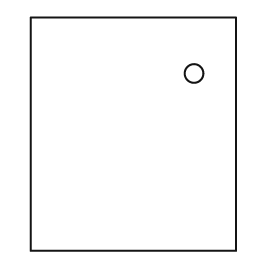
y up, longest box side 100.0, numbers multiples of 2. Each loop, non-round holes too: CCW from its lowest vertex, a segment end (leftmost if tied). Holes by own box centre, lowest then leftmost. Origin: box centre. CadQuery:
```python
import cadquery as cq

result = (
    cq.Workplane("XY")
    .moveTo(-44.0, -50.0)
    .lineTo(44.0, -50.0)
    .lineTo(44.0, 50.0)
    .lineTo(-44.0, 50.0)
    .close()
    .moveTo(26.0, 26.0)
    .circle(4.0)
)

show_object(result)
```